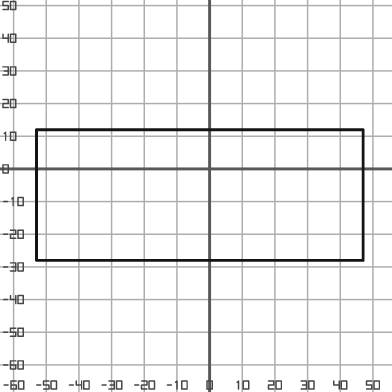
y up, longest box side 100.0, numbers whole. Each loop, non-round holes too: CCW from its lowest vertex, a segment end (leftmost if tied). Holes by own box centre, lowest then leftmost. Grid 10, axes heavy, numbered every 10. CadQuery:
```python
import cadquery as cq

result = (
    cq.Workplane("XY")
    .moveTo(-53.0, -28.0)
    .lineTo(47.0, -28.0)
    .lineTo(47.0, 12.0)
    .lineTo(-53.0, 12.0)
    .close()
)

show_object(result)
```